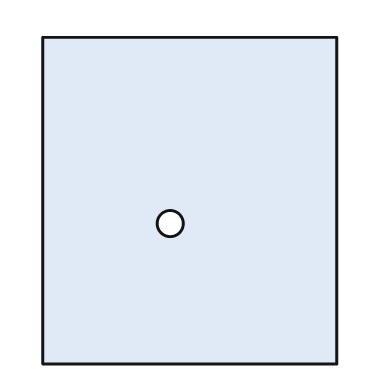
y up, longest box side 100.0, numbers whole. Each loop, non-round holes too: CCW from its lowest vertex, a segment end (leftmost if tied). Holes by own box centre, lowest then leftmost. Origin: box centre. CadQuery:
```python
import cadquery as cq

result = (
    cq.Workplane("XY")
    .moveTo(-45.0, -50.0)
    .lineTo(45.0, -50.0)
    .lineTo(45.0, 50.0)
    .lineTo(-45.0, 50.0)
    .close()
    .moveTo(-6.0, -7.0)
    .circle(4.0)
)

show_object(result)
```